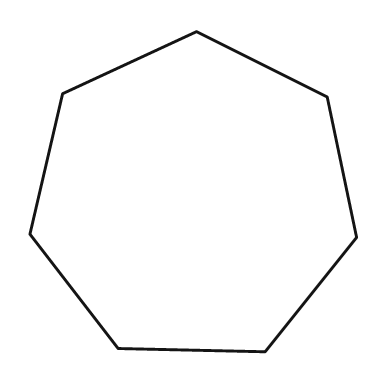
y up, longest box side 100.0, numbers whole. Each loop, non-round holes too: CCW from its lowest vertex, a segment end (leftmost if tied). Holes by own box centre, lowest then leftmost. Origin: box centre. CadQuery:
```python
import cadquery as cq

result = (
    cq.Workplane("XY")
    .moveTo(22.0, -49.0)
    .lineTo(50.0, -14.0)
    .lineTo(41.0, 29.0)
    .lineTo(1.0, 49.0)
    .lineTo(-40.0, 30.0)
    .lineTo(-50.0, -13.0)
    .lineTo(-23.0, -48.0)
    .close()
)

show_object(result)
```